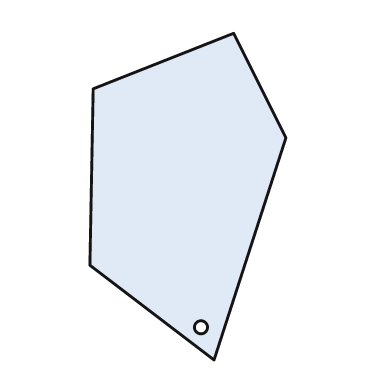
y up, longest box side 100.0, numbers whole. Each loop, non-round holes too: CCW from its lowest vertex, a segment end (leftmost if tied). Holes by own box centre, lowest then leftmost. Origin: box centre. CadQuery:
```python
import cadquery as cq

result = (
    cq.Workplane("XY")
    .moveTo(8.0, -50.0)
    .lineTo(30.0, 18.0)
    .lineTo(14.0, 50.0)
    .lineTo(-29.0, 33.0)
    .lineTo(-30.0, -21.0)
    .close()
    .moveTo(4.0, -40.0)
    .circle(2.0)
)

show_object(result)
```